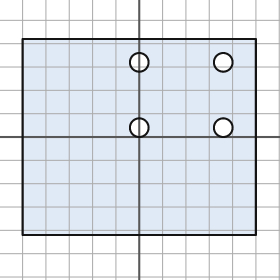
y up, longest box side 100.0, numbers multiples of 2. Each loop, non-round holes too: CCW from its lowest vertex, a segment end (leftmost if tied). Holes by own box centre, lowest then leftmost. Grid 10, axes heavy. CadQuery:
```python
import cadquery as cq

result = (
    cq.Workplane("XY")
    .moveTo(-50.0, -42.0)
    .lineTo(50.0, -42.0)
    .lineTo(50.0, 42.0)
    .lineTo(-50.0, 42.0)
    .close()
    .moveTo(0.0, 4.0)
    .circle(4.0)
    .moveTo(36.0, 4.0)
    .circle(4.0)
    .moveTo(0.0, 32.0)
    .circle(4.0)
    .moveTo(36.0, 32.0)
    .circle(4.0)
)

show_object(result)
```